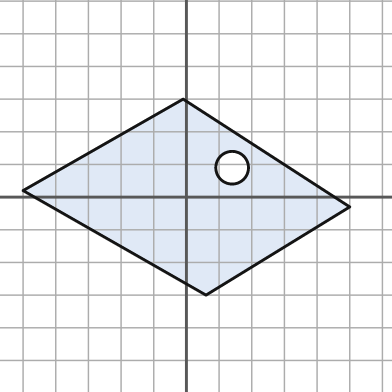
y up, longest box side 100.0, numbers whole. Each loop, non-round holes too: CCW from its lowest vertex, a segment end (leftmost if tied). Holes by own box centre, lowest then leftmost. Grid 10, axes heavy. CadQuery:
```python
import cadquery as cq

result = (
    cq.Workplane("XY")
    .moveTo(6.0, -30.0)
    .lineTo(50.0, -3.0)
    .lineTo(-1.0, 30.0)
    .lineTo(-50.0, 2.0)
    .close()
    .moveTo(14.0, 9.0)
    .circle(5.0)
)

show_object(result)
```